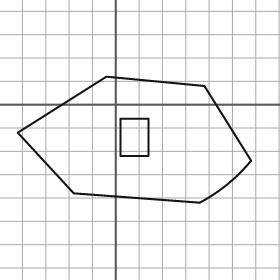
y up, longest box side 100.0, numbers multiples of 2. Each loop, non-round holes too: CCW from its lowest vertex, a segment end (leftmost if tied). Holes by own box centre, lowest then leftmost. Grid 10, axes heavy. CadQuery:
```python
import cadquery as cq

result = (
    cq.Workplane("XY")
    .moveTo(36.0, -42.0)
    .threePointArc((48.0, -34.0), (58.0, -24.0))
    .lineTo(38.0, 8.0)
    .lineTo(-4.0, 12.0)
    .lineTo(-42.0, -12.0)
    .lineTo(-18.0, -38.0)
    .close()
    .moveTo(2.0, -22.0)
    .lineTo(14.0, -22.0)
    .lineTo(14.0, -6.0)
    .lineTo(2.0, -6.0)
    .close()
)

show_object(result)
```